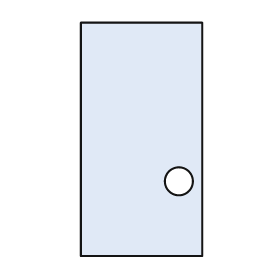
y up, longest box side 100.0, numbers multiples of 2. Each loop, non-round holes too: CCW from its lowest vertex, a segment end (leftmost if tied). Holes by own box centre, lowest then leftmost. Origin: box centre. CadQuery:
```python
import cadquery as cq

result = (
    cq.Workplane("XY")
    .moveTo(-26.0, -50.0)
    .lineTo(26.0, -50.0)
    .lineTo(26.0, 50.0)
    .lineTo(-26.0, 50.0)
    .close()
    .moveTo(16.0, -18.0)
    .circle(6.0)
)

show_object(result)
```